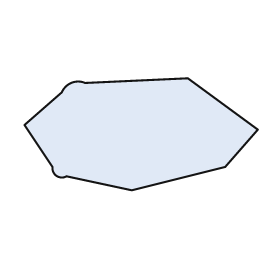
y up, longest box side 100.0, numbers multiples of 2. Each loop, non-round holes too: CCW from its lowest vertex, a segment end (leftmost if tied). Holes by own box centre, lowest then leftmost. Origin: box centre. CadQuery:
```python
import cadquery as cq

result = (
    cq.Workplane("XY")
    .moveTo(-4.0, -24.0)
    .lineTo(36.0, -14.0)
    .lineTo(50.0, 2.0)
    .lineTo(20.0, 24.0)
    .lineTo(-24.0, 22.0)
    .threePointArc((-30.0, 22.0), (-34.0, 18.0))
    .lineTo(-50.0, 4.0)
    .lineTo(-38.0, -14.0)
    .threePointArc((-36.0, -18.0), (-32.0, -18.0))
    .close()
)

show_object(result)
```